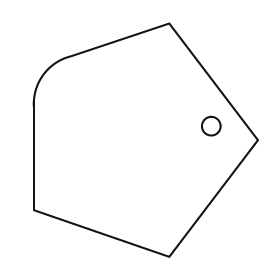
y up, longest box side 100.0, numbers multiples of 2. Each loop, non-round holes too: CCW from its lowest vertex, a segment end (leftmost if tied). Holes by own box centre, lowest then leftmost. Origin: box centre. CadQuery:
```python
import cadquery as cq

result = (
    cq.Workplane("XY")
    .moveTo(10.0, -50.0)
    .lineTo(48.0, 0.0)
    .lineTo(10.0, 50.0)
    .lineTo(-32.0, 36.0)
    .threePointArc((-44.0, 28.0), (-48.0, 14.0))
    .lineTo(-48.0, -30.0)
    .close()
    .moveTo(28.0, 6.0)
    .circle(4.0)
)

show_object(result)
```